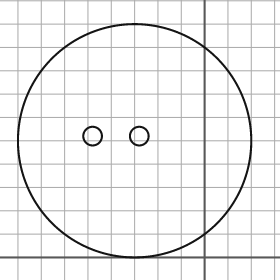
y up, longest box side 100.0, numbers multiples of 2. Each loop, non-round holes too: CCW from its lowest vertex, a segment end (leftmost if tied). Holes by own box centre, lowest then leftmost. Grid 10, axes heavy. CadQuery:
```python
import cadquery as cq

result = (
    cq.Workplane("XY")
    .moveTo(-30.0, 50.0)
    .circle(50.0)
    .moveTo(-48.0, 52.0)
    .circle(4.0)
    .moveTo(-28.0, 52.0)
    .circle(4.0)
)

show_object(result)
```